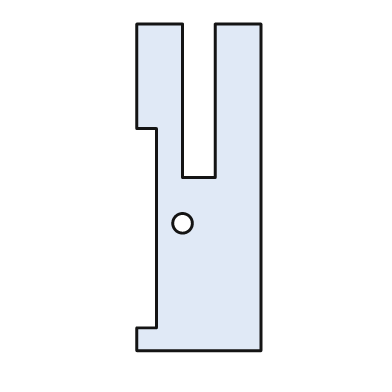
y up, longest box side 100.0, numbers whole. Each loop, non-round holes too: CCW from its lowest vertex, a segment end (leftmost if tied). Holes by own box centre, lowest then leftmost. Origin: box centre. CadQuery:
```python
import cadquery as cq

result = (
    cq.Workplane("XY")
    .moveTo(-19.0, -50.0)
    .lineTo(19.0, -50.0)
    .lineTo(19.0, 50.0)
    .lineTo(5.0, 50.0)
    .lineTo(5.0, 3.0)
    .lineTo(-5.0, 3.0)
    .lineTo(-5.0, 50.0)
    .lineTo(-19.0, 50.0)
    .lineTo(-19.0, 18.0)
    .lineTo(-13.0, 18.0)
    .lineTo(-13.0, -43.0)
    .lineTo(-19.0, -43.0)
    .close()
    .moveTo(-5.0, -11.0)
    .circle(3.0)
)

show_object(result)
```